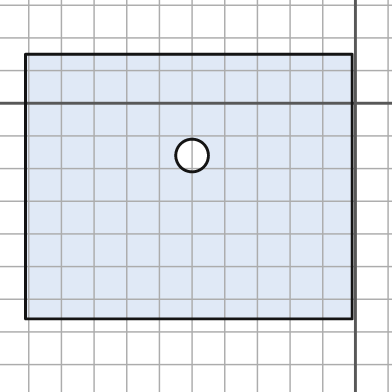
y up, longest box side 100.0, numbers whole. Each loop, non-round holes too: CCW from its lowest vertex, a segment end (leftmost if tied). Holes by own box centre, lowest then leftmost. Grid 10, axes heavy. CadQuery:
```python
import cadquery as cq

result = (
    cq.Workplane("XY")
    .moveTo(-101.0, -66.0)
    .lineTo(-1.0, -66.0)
    .lineTo(-1.0, 15.0)
    .lineTo(-101.0, 15.0)
    .close()
    .moveTo(-50.0, -16.0)
    .circle(5.0)
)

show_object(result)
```